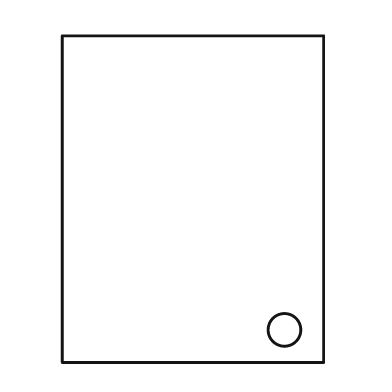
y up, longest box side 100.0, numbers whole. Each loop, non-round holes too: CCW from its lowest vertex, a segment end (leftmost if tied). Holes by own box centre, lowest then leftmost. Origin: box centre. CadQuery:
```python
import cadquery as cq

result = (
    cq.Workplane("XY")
    .moveTo(-40.0, -50.0)
    .lineTo(40.0, -50.0)
    .lineTo(40.0, 50.0)
    .lineTo(-40.0, 50.0)
    .close()
    .moveTo(28.0, -40.0)
    .circle(5.0)
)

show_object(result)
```